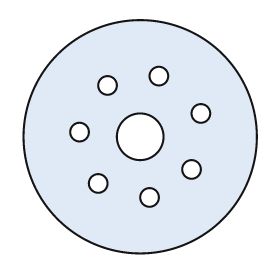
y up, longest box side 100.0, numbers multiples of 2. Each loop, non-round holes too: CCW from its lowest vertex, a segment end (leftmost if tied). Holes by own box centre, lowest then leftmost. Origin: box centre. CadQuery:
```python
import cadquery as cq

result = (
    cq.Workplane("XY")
    .moveTo(0.0, 0.0)
    .circle(50.0)
    .moveTo(4.0, -26.0)
    .circle(4.0)
    .moveTo(-18.0, -20.0)
    .circle(4.0)
    .moveTo(22.0, -14.0)
    .circle(4.0)
    .moveTo(0.0, 0.0)
    .circle(10.0)
    .moveTo(-26.0, 2.0)
    .circle(4.0)
    .moveTo(26.0, 10.0)
    .circle(4.0)
    .moveTo(-14.0, 22.0)
    .circle(4.0)
    .moveTo(8.0, 26.0)
    .circle(4.0)
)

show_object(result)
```